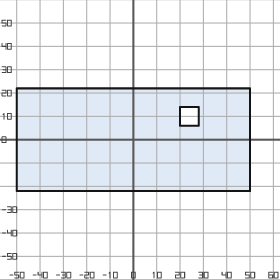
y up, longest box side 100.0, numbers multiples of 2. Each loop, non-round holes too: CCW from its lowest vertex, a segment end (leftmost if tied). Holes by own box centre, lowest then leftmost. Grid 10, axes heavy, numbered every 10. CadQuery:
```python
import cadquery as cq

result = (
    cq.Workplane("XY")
    .moveTo(-50.0, -22.0)
    .lineTo(50.0, -22.0)
    .lineTo(50.0, 22.0)
    .lineTo(-50.0, 22.0)
    .close()
    .moveTo(20.0, 6.0)
    .lineTo(28.0, 6.0)
    .lineTo(28.0, 14.0)
    .lineTo(20.0, 14.0)
    .close()
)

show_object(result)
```